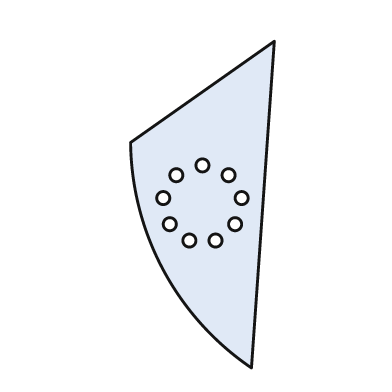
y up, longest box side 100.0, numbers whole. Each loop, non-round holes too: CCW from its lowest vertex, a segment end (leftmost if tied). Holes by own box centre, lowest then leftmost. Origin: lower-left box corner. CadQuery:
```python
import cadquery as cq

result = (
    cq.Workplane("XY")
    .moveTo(37.0, 0.0)
    .lineTo(44.0, 100.0)
    .lineTo(0.0, 69.0)
    .threePointArc((10.0, 30.0), (37.0, 0.0))
    .close()
    .moveTo(18.0, 39.0)
    .circle(2.0)
    .moveTo(26.0, 39.0)
    .circle(2.0)
    .moveTo(12.0, 44.0)
    .circle(2.0)
    .moveTo(32.0, 44.0)
    .circle(2.0)
    .moveTo(10.0, 52.0)
    .circle(2.0)
    .moveTo(34.0, 52.0)
    .circle(2.0)
    .moveTo(14.0, 59.0)
    .circle(2.0)
    .moveTo(30.0, 59.0)
    .circle(2.0)
    .moveTo(22.0, 62.0)
    .circle(2.0)
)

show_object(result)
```